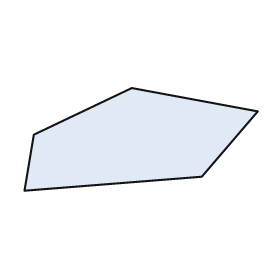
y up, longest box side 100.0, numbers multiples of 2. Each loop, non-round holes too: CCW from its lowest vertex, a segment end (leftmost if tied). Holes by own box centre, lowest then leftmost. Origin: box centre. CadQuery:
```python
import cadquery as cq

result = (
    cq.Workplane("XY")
    .moveTo(-50.0, -22.0)
    .lineTo(26.0, -16.0)
    .lineTo(50.0, 12.0)
    .lineTo(-4.0, 22.0)
    .lineTo(-46.0, 2.0)
    .close()
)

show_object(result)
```